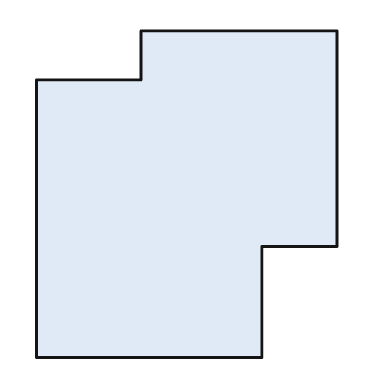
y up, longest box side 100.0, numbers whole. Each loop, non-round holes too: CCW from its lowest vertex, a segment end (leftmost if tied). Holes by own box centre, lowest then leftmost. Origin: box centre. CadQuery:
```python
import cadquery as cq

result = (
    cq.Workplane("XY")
    .moveTo(-46.0, -50.0)
    .lineTo(23.0, -50.0)
    .lineTo(23.0, -16.0)
    .lineTo(46.0, -16.0)
    .lineTo(46.0, 50.0)
    .lineTo(-14.0, 50.0)
    .lineTo(-14.0, 35.0)
    .lineTo(-46.0, 35.0)
    .close()
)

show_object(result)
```